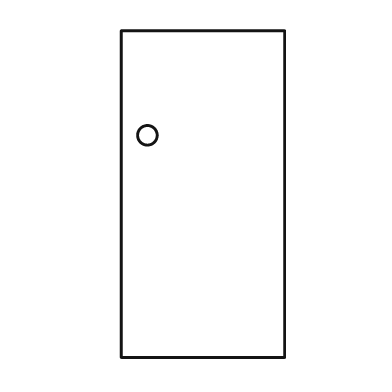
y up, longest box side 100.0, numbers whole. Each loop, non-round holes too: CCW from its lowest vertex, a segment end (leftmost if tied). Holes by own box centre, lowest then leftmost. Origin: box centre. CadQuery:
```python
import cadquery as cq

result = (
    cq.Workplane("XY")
    .moveTo(-25.0, -50.0)
    .lineTo(25.0, -50.0)
    .lineTo(25.0, 50.0)
    .lineTo(-25.0, 50.0)
    .close()
    .moveTo(-17.0, 18.0)
    .circle(3.0)
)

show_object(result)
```